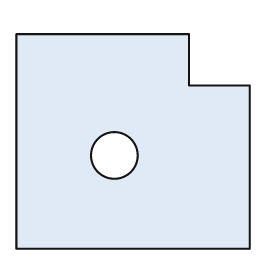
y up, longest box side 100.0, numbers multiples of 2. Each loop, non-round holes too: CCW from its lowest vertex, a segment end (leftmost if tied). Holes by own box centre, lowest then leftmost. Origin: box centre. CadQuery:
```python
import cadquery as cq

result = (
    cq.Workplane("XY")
    .moveTo(-50.0, -46.0)
    .lineTo(50.0, -46.0)
    .lineTo(50.0, 24.0)
    .lineTo(24.0, 24.0)
    .lineTo(24.0, 46.0)
    .lineTo(-50.0, 46.0)
    .close()
    .moveTo(-8.0, -6.0)
    .circle(10.0)
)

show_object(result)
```